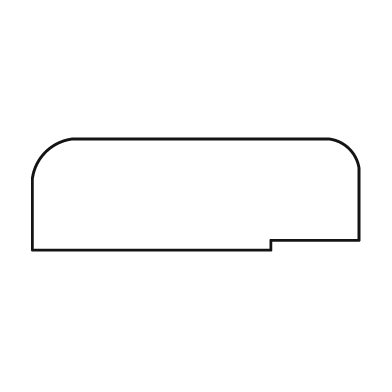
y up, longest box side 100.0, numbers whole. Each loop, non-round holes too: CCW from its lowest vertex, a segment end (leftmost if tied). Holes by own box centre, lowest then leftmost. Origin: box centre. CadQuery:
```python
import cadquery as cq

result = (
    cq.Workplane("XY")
    .moveTo(-50.0, -17.0)
    .lineTo(23.0, -17.0)
    .lineTo(23.0, -14.0)
    .lineTo(50.0, -14.0)
    .lineTo(50.0, 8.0)
    .threePointArc((47.0, 14.0), (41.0, 17.0))
    .lineTo(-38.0, 17.0)
    .threePointArc((-46.0, 13.0), (-50.0, 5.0))
    .close()
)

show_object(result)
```